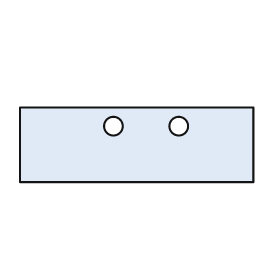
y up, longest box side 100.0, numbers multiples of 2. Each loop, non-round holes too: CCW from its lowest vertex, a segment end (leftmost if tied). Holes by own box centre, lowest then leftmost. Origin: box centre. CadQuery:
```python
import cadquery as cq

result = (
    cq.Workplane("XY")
    .moveTo(-50.0, -16.0)
    .lineTo(50.0, -16.0)
    .lineTo(50.0, 16.0)
    .lineTo(-50.0, 16.0)
    .close()
    .moveTo(-10.0, 8.0)
    .circle(4.0)
    .moveTo(18.0, 8.0)
    .circle(4.0)
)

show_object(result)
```